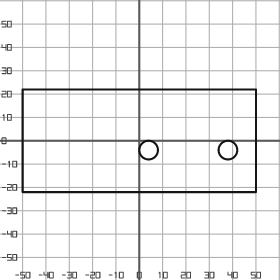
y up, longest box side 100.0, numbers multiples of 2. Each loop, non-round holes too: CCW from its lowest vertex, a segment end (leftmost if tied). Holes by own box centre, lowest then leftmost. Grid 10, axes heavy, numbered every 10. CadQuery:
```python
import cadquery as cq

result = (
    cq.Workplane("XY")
    .moveTo(-50.0, -22.0)
    .lineTo(50.0, -22.0)
    .lineTo(50.0, 22.0)
    .lineTo(-50.0, 22.0)
    .close()
    .moveTo(4.0, -4.0)
    .circle(4.0)
    .moveTo(38.0, -4.0)
    .circle(4.0)
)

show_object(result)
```